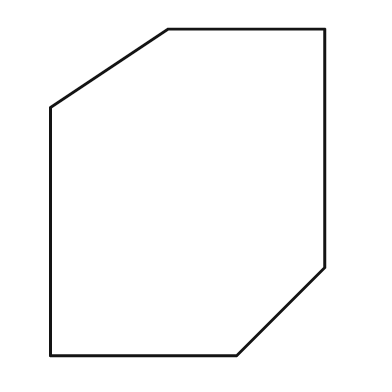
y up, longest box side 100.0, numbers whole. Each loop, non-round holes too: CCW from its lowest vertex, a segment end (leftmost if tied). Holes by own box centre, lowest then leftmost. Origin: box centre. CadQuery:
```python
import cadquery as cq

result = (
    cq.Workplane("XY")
    .moveTo(-42.0, -50.0)
    .lineTo(15.0, -50.0)
    .lineTo(42.0, -23.0)
    .lineTo(42.0, 50.0)
    .lineTo(-6.0, 50.0)
    .lineTo(-42.0, 26.0)
    .close()
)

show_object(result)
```